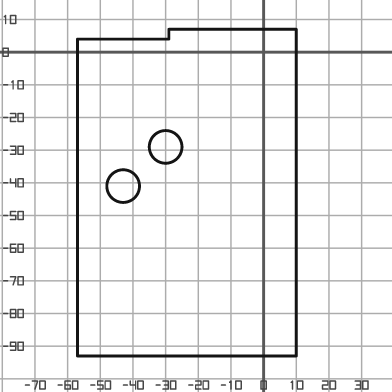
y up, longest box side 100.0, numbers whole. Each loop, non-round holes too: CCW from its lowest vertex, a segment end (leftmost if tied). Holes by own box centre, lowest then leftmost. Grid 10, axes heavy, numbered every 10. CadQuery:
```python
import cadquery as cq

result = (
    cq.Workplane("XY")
    .moveTo(-57.0, -93.0)
    .lineTo(10.0, -93.0)
    .lineTo(10.0, 7.0)
    .lineTo(-29.0, 7.0)
    .lineTo(-29.0, 4.0)
    .lineTo(-57.0, 4.0)
    .close()
    .moveTo(-43.0, -41.0)
    .circle(5.0)
    .moveTo(-30.0, -29.0)
    .circle(5.0)
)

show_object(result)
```